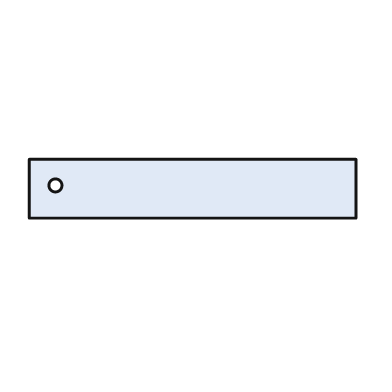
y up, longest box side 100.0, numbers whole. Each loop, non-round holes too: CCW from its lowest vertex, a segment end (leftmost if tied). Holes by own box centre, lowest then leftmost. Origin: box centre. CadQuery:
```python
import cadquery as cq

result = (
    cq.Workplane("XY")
    .moveTo(-50.0, -9.0)
    .lineTo(50.0, -9.0)
    .lineTo(50.0, 9.0)
    .lineTo(-50.0, 9.0)
    .close()
    .moveTo(-42.0, 1.0)
    .circle(2.0)
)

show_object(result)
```